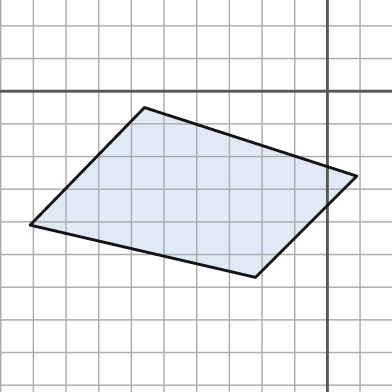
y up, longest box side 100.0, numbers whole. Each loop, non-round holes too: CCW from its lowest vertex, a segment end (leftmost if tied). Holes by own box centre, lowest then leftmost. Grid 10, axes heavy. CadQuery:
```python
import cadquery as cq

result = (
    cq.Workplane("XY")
    .moveTo(-22.0, -57.0)
    .lineTo(9.0, -26.0)
    .lineTo(-56.0, -5.0)
    .lineTo(-91.0, -41.0)
    .close()
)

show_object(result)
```